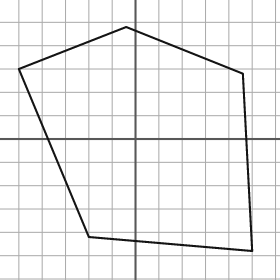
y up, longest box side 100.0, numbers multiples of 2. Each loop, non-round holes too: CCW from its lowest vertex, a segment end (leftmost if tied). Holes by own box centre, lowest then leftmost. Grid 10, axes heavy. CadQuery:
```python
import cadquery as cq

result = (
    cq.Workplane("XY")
    .moveTo(50.0, -48.0)
    .lineTo(46.0, 28.0)
    .lineTo(-4.0, 48.0)
    .lineTo(-50.0, 30.0)
    .lineTo(-20.0, -42.0)
    .close()
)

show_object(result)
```